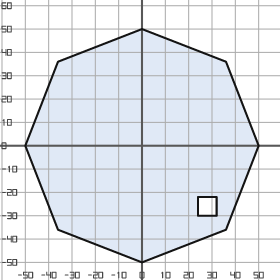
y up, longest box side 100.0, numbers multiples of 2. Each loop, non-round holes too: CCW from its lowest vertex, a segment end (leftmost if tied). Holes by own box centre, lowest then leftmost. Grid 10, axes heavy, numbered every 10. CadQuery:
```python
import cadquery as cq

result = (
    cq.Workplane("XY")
    .moveTo(0.0, -50.0)
    .lineTo(36.0, -36.0)
    .lineTo(50.0, 0.0)
    .lineTo(36.0, 36.0)
    .lineTo(0.0, 50.0)
    .lineTo(-36.0, 36.0)
    .lineTo(-50.0, 0.0)
    .lineTo(-36.0, -36.0)
    .close()
    .moveTo(24.0, -30.0)
    .lineTo(32.0, -30.0)
    .lineTo(32.0, -22.0)
    .lineTo(24.0, -22.0)
    .close()
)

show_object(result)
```